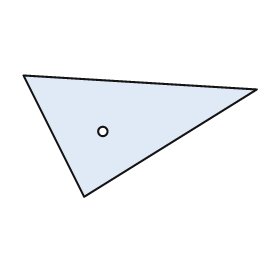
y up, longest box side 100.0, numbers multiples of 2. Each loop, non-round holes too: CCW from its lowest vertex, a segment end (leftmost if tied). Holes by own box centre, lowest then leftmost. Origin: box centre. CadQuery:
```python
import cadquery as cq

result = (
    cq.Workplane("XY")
    .moveTo(-24.0, -26.0)
    .lineTo(50.0, 20.0)
    .lineTo(-50.0, 26.0)
    .close()
    .moveTo(-16.0, 2.0)
    .circle(2.0)
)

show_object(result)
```